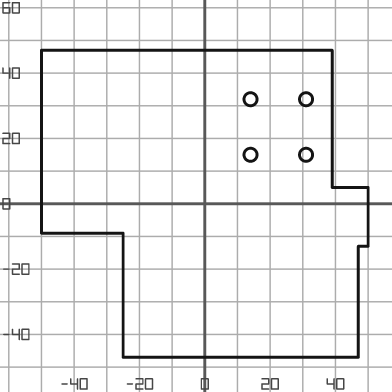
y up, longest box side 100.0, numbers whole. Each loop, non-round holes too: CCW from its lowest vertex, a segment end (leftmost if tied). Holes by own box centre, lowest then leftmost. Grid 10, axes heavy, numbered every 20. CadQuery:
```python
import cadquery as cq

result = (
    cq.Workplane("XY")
    .moveTo(-25.0, -47.0)
    .lineTo(47.0, -47.0)
    .lineTo(47.0, -13.0)
    .lineTo(50.0, -13.0)
    .lineTo(50.0, 5.0)
    .lineTo(39.0, 5.0)
    .lineTo(39.0, 47.0)
    .lineTo(-50.0, 47.0)
    .lineTo(-50.0, -9.0)
    .lineTo(-25.0, -9.0)
    .close()
    .moveTo(14.0, 15.0)
    .circle(2.0)
    .moveTo(31.0, 15.0)
    .circle(2.0)
    .moveTo(14.0, 32.0)
    .circle(2.0)
    .moveTo(31.0, 32.0)
    .circle(2.0)
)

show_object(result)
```